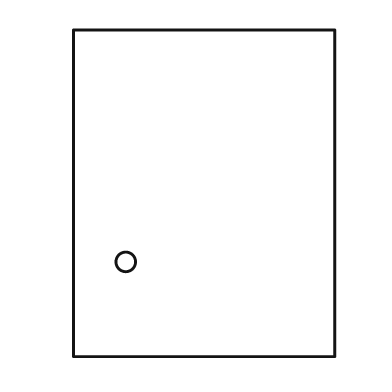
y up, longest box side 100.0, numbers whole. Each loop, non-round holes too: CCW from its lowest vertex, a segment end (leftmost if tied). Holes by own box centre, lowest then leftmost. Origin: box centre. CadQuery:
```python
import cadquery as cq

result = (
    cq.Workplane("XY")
    .moveTo(-40.0, -50.0)
    .lineTo(40.0, -50.0)
    .lineTo(40.0, 50.0)
    .lineTo(-40.0, 50.0)
    .close()
    .moveTo(-24.0, -21.0)
    .circle(3.0)
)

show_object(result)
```